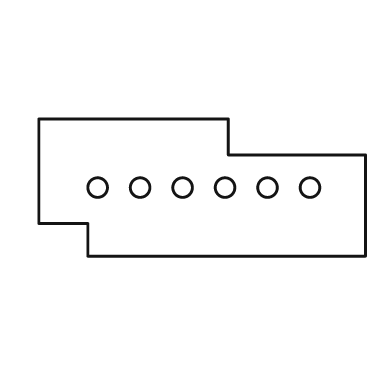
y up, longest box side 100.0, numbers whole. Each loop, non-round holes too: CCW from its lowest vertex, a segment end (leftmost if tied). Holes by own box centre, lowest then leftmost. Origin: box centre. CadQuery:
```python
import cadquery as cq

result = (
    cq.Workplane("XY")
    .moveTo(-35.0, -21.0)
    .lineTo(50.0, -21.0)
    .lineTo(50.0, 10.0)
    .lineTo(8.0, 10.0)
    .lineTo(8.0, 21.0)
    .lineTo(-50.0, 21.0)
    .lineTo(-50.0, -11.0)
    .lineTo(-35.0, -11.0)
    .close()
    .moveTo(-32.0, 0.0)
    .circle(3.0)
    .moveTo(-19.0, 0.0)
    .circle(3.0)
    .moveTo(-6.0, 0.0)
    .circle(3.0)
    .moveTo(7.0, 0.0)
    .circle(3.0)
    .moveTo(20.0, 0.0)
    .circle(3.0)
    .moveTo(33.0, 0.0)
    .circle(3.0)
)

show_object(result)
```